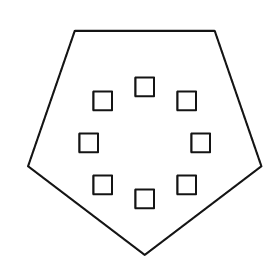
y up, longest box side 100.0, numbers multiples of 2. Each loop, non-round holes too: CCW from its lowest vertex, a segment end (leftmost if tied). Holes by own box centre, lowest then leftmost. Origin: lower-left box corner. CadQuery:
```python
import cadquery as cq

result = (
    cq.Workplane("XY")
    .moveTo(50.0, 0.0)
    .lineTo(100.0, 38.0)
    .lineTo(80.0, 96.0)
    .lineTo(20.0, 96.0)
    .lineTo(0.0, 38.0)
    .close()
    .moveTo(46.0, 20.0)
    .lineTo(54.0, 20.0)
    .lineTo(54.0, 28.0)
    .lineTo(46.0, 28.0)
    .close()
    .moveTo(28.0, 26.0)
    .lineTo(36.0, 26.0)
    .lineTo(36.0, 34.0)
    .lineTo(28.0, 34.0)
    .close()
    .moveTo(64.0, 26.0)
    .lineTo(72.0, 26.0)
    .lineTo(72.0, 34.0)
    .lineTo(64.0, 34.0)
    .close()
    .moveTo(22.0, 44.0)
    .lineTo(30.0, 44.0)
    .lineTo(30.0, 52.0)
    .lineTo(22.0, 52.0)
    .close()
    .moveTo(70.0, 44.0)
    .lineTo(78.0, 44.0)
    .lineTo(78.0, 52.0)
    .lineTo(70.0, 52.0)
    .close()
    .moveTo(28.0, 62.0)
    .lineTo(36.0, 62.0)
    .lineTo(36.0, 70.0)
    .lineTo(28.0, 70.0)
    .close()
    .moveTo(64.0, 62.0)
    .lineTo(72.0, 62.0)
    .lineTo(72.0, 70.0)
    .lineTo(64.0, 70.0)
    .close()
    .moveTo(46.0, 68.0)
    .lineTo(54.0, 68.0)
    .lineTo(54.0, 76.0)
    .lineTo(46.0, 76.0)
    .close()
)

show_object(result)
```